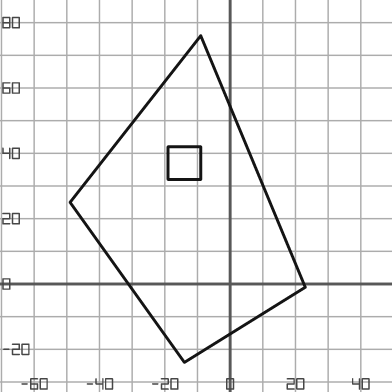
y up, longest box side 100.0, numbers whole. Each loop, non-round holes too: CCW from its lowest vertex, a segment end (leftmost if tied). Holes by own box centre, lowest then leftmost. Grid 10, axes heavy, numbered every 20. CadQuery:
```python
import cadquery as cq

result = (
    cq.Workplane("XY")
    .moveTo(-14.0, -24.0)
    .lineTo(23.0, -1.0)
    .lineTo(-9.0, 76.0)
    .lineTo(-49.0, 25.0)
    .close()
    .moveTo(-19.0, 32.0)
    .lineTo(-9.0, 32.0)
    .lineTo(-9.0, 42.0)
    .lineTo(-19.0, 42.0)
    .close()
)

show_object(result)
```